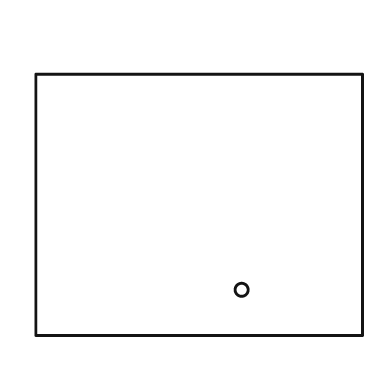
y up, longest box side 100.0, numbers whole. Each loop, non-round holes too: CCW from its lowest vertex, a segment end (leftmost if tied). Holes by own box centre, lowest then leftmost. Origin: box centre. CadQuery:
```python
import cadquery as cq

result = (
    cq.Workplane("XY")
    .moveTo(-50.0, -40.0)
    .lineTo(50.0, -40.0)
    .lineTo(50.0, 40.0)
    .lineTo(-50.0, 40.0)
    .close()
    .moveTo(13.0, -26.0)
    .circle(2.0)
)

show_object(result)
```